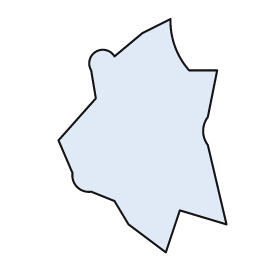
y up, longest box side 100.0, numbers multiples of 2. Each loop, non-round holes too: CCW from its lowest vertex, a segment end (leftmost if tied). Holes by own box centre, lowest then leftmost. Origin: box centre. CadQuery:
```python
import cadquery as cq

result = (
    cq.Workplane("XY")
    .moveTo(10.0, -50.0)
    .lineTo(16.0, -32.0)
    .lineTo(36.0, -38.0)
    .lineTo(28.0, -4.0)
    .threePointArc((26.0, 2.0), (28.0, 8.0))
    .lineTo(32.0, 28.0)
    .lineTo(20.0, 28.0)
    .threePointArc((14.0, 38.0), (12.0, 50.0))
    .lineTo(0.0, 44.0)
    .lineTo(-12.0, 34.0)
    .threePointArc((-20.0, 36.0), (-22.0, 28.0))
    .lineTo(-20.0, 16.0)
    .lineTo(-36.0, -2.0)
    .lineTo(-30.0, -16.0)
    .threePointArc((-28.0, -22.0), (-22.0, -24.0))
    .lineTo(-12.0, -28.0)
    .lineTo(-6.0, -38.0)
    .close()
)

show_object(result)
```